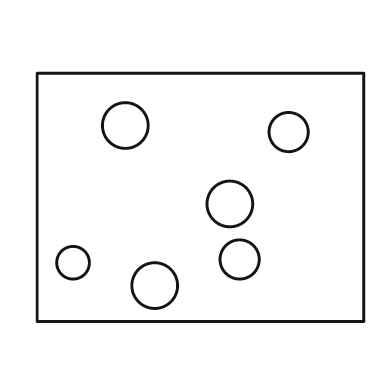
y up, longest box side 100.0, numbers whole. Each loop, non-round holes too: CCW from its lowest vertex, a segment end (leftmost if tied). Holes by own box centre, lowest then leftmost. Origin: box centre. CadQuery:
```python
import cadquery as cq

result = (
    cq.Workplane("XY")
    .moveTo(-50.0, -38.0)
    .lineTo(50.0, -38.0)
    .lineTo(50.0, 38.0)
    .lineTo(-50.0, 38.0)
    .close()
    .moveTo(-14.0, -27.0)
    .circle(7.0)
    .moveTo(-39.0, -20.0)
    .circle(5.0)
    .moveTo(12.0, -19.0)
    .circle(6.0)
    .moveTo(9.0, -2.0)
    .circle(7.0)
    .moveTo(27.0, 20.0)
    .circle(6.0)
    .moveTo(-23.0, 22.0)
    .circle(7.0)
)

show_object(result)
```